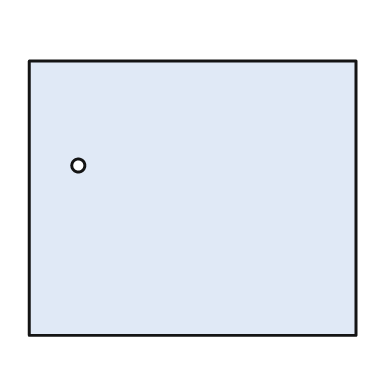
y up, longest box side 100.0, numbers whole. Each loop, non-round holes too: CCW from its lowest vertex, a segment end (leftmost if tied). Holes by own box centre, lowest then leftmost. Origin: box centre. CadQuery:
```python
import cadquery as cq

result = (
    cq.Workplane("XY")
    .moveTo(-50.0, -42.0)
    .lineTo(50.0, -42.0)
    .lineTo(50.0, 42.0)
    .lineTo(-50.0, 42.0)
    .close()
    .moveTo(-35.0, 10.0)
    .circle(2.0)
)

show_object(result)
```